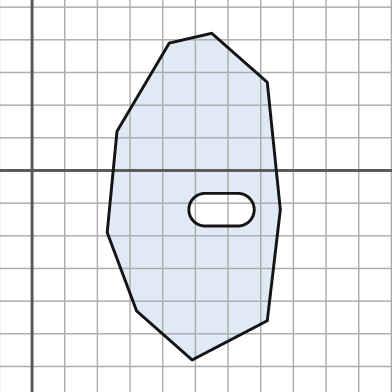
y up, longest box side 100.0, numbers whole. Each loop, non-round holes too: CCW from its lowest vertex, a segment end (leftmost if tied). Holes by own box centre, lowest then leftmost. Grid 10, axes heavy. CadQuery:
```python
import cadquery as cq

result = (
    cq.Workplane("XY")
    .moveTo(49.0, -58.0)
    .lineTo(72.0, -46.0)
    .lineTo(76.0, -12.0)
    .lineTo(72.0, 27.0)
    .lineTo(55.0, 42.0)
    .lineTo(42.0, 39.0)
    .lineTo(26.0, 12.0)
    .lineTo(23.0, -19.0)
    .lineTo(32.0, -43.0)
    .close()
    .moveTo(53.0, -17.0)
    .lineTo(63.0, -17.0)
    .threePointArc((68.0, -12.0), (63.0, -7.0))
    .lineTo(53.0, -7.0)
    .threePointArc((48.0, -12.0), (53.0, -17.0))
    .close()
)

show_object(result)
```